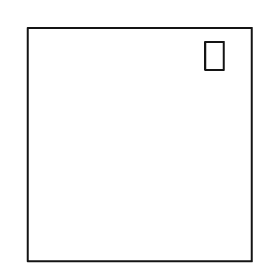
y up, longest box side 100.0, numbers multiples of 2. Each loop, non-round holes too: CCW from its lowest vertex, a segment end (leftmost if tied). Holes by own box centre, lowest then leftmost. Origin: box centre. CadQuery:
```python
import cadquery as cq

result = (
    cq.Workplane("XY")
    .moveTo(-48.0, -50.0)
    .lineTo(48.0, -50.0)
    .lineTo(48.0, 50.0)
    .lineTo(-48.0, 50.0)
    .close()
    .moveTo(28.0, 32.0)
    .lineTo(36.0, 32.0)
    .lineTo(36.0, 44.0)
    .lineTo(28.0, 44.0)
    .close()
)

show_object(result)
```